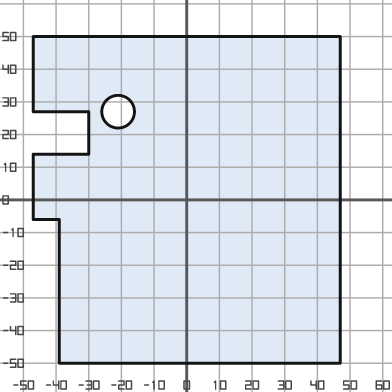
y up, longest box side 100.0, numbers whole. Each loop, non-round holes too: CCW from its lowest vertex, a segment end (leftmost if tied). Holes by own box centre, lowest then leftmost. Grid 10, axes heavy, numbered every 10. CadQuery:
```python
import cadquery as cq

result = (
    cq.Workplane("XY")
    .moveTo(-39.0, -50.0)
    .lineTo(47.0, -50.0)
    .lineTo(47.0, 50.0)
    .lineTo(-47.0, 50.0)
    .lineTo(-47.0, 27.0)
    .lineTo(-30.0, 27.0)
    .lineTo(-30.0, 14.0)
    .lineTo(-47.0, 14.0)
    .lineTo(-47.0, -6.0)
    .lineTo(-39.0, -6.0)
    .close()
    .moveTo(-21.0, 27.0)
    .circle(5.0)
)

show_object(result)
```